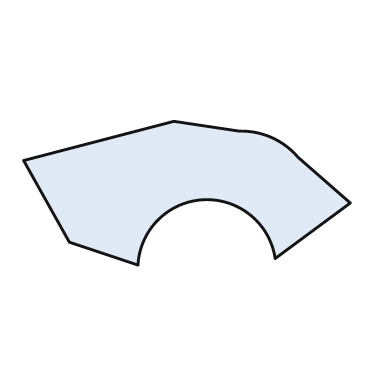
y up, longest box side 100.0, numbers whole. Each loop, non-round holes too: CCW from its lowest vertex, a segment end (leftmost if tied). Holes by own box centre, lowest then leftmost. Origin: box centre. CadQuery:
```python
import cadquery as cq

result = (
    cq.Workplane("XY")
    .moveTo(-15.0, -22.0)
    .threePointArc((5.0, -2.0), (27.0, -20.0))
    .lineTo(50.0, -3.0)
    .lineTo(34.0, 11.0)
    .threePointArc((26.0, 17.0), (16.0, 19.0))
    .lineTo(-4.0, 22.0)
    .lineTo(-50.0, 10.0)
    .lineTo(-36.0, -15.0)
    .close()
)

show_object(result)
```